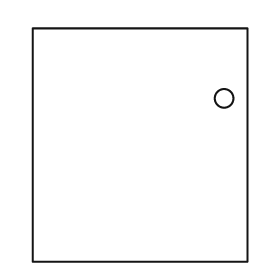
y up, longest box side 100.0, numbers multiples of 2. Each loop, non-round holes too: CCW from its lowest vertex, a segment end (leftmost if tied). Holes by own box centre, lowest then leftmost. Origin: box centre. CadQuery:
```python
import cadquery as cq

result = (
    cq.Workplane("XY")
    .moveTo(-46.0, -50.0)
    .lineTo(46.0, -50.0)
    .lineTo(46.0, 50.0)
    .lineTo(-46.0, 50.0)
    .close()
    .moveTo(36.0, 20.0)
    .circle(4.0)
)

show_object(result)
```